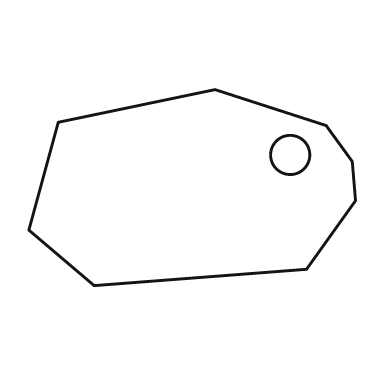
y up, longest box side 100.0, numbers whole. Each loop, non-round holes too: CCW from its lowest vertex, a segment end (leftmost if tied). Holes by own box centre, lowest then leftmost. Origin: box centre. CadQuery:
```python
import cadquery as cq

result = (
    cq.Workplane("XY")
    .moveTo(-30.0, -30.0)
    .lineTo(35.0, -25.0)
    .lineTo(50.0, -4.0)
    .lineTo(49.0, 8.0)
    .lineTo(41.0, 19.0)
    .lineTo(7.0, 30.0)
    .lineTo(-41.0, 20.0)
    .lineTo(-50.0, -13.0)
    .close()
    .moveTo(30.0, 10.0)
    .circle(6.0)
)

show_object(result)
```